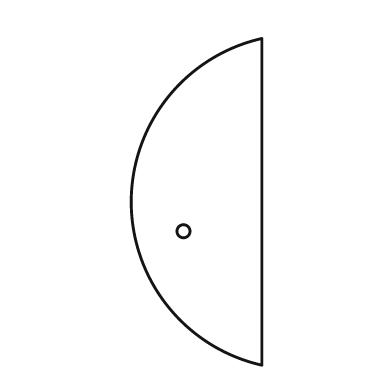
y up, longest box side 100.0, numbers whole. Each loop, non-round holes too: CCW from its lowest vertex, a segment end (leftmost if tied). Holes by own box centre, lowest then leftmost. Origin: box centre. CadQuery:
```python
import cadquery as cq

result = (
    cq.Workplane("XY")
    .moveTo(20.0, -50.0)
    .lineTo(20.0, 50.0)
    .threePointArc((-20.0, 0.0), (20.0, -50.0))
    .close()
    .moveTo(-4.0, -9.0)
    .circle(2.0)
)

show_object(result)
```